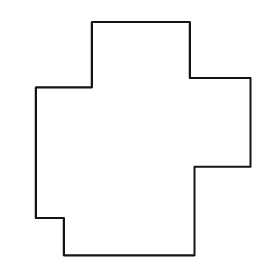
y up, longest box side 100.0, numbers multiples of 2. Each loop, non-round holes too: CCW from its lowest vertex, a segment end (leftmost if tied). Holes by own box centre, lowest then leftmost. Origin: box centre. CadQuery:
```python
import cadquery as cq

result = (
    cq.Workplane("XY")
    .moveTo(-34.0, -50.0)
    .lineTo(22.0, -50.0)
    .lineTo(22.0, -12.0)
    .lineTo(46.0, -12.0)
    .lineTo(46.0, 26.0)
    .lineTo(20.0, 26.0)
    .lineTo(20.0, 50.0)
    .lineTo(-22.0, 50.0)
    .lineTo(-22.0, 22.0)
    .lineTo(-46.0, 22.0)
    .lineTo(-46.0, -34.0)
    .lineTo(-34.0, -34.0)
    .close()
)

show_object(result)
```